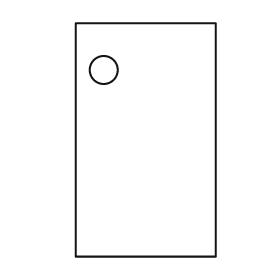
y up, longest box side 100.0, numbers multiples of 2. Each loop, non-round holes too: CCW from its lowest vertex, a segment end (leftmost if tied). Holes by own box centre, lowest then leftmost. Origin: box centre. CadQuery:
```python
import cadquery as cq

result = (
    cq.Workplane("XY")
    .moveTo(-30.0, -50.0)
    .lineTo(30.0, -50.0)
    .lineTo(30.0, 50.0)
    .lineTo(-30.0, 50.0)
    .close()
    .moveTo(-18.0, 30.0)
    .circle(6.0)
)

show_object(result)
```